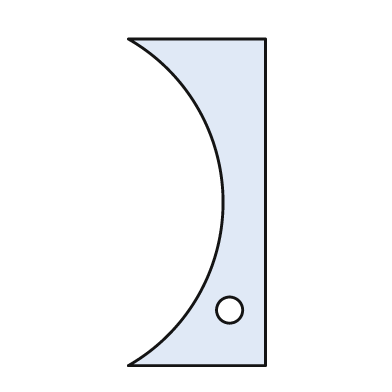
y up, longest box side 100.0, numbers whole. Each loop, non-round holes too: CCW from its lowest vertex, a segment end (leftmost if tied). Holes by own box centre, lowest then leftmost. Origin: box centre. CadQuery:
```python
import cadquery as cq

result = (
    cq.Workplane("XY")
    .moveTo(-21.0, -50.0)
    .lineTo(21.0, -50.0)
    .lineTo(21.0, 50.0)
    .lineTo(-21.0, 50.0)
    .threePointArc((8.0, 0.0), (-21.0, -50.0))
    .close()
    .moveTo(10.0, -33.0)
    .circle(4.0)
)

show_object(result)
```